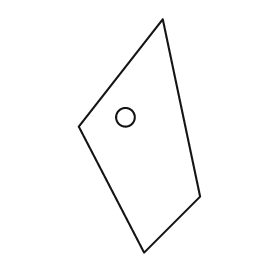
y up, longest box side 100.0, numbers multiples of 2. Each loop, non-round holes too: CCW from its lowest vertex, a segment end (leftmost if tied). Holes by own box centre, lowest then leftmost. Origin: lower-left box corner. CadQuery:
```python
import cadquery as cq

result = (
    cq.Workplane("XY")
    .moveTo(28.0, 0.0)
    .lineTo(52.0, 24.0)
    .lineTo(36.0, 100.0)
    .lineTo(0.0, 54.0)
    .close()
    .moveTo(20.0, 58.0)
    .circle(4.0)
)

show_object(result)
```